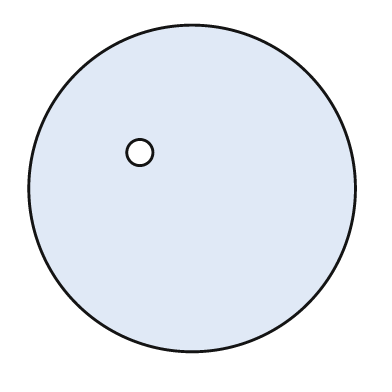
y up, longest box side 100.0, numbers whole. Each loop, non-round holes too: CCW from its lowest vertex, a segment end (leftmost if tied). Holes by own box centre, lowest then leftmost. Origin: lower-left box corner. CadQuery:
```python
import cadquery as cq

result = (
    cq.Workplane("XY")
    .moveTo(50.0, 50.0)
    .circle(50.0)
    .moveTo(34.0, 61.0)
    .circle(4.0)
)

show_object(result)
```